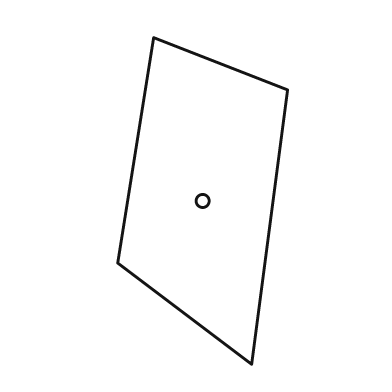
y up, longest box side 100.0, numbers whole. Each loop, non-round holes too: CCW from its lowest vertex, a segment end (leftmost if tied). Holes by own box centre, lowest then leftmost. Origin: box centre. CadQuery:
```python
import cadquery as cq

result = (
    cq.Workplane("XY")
    .moveTo(15.0, -50.0)
    .lineTo(26.0, 34.0)
    .lineTo(-15.0, 50.0)
    .lineTo(-26.0, -19.0)
    .close()
    .moveTo(0.0, 0.0)
    .circle(2.0)
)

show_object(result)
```